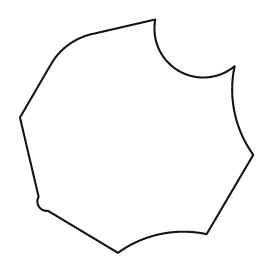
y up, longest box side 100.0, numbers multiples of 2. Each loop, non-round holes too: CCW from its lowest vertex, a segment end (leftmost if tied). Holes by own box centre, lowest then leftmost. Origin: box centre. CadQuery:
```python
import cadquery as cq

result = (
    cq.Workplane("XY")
    .moveTo(-8.0, -50.0)
    .threePointArc((10.0, -42.0), (30.0, -42.0))
    .lineTo(50.0, -8.0)
    .threePointArc((42.0, 10.0), (42.0, 30.0))
    .threePointArc((18.0, 28.0), (8.0, 50.0))
    .lineTo(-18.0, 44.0)
    .threePointArc((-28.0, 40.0), (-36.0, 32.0))
    .lineTo(-50.0, 8.0)
    .lineTo(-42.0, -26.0)
    .threePointArc((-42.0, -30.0), (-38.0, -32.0))
    .close()
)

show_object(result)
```